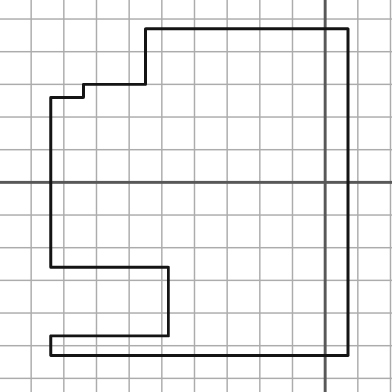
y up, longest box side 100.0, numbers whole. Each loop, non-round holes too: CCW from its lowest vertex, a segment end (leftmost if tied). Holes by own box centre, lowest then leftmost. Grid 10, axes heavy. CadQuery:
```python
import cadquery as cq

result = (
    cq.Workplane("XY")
    .moveTo(-84.0, -53.0)
    .lineTo(7.0, -53.0)
    .lineTo(7.0, 47.0)
    .lineTo(-55.0, 47.0)
    .lineTo(-55.0, 30.0)
    .lineTo(-74.0, 30.0)
    .lineTo(-74.0, 26.0)
    .lineTo(-84.0, 26.0)
    .lineTo(-84.0, -26.0)
    .lineTo(-48.0, -26.0)
    .lineTo(-48.0, -47.0)
    .lineTo(-84.0, -47.0)
    .close()
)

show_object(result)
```